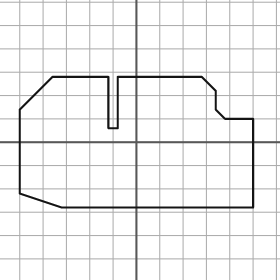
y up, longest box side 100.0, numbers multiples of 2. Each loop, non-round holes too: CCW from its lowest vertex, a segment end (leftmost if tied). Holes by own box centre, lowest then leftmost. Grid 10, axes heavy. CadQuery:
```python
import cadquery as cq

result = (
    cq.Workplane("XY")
    .moveTo(-32.0, -28.0)
    .lineTo(50.0, -28.0)
    .lineTo(50.0, 10.0)
    .lineTo(38.0, 10.0)
    .lineTo(34.0, 14.0)
    .lineTo(34.0, 22.0)
    .lineTo(28.0, 28.0)
    .lineTo(-8.0, 28.0)
    .lineTo(-8.0, 6.0)
    .lineTo(-12.0, 6.0)
    .lineTo(-12.0, 28.0)
    .lineTo(-36.0, 28.0)
    .lineTo(-50.0, 14.0)
    .lineTo(-50.0, -22.0)
    .close()
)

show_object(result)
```